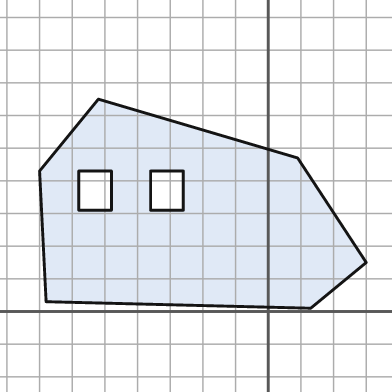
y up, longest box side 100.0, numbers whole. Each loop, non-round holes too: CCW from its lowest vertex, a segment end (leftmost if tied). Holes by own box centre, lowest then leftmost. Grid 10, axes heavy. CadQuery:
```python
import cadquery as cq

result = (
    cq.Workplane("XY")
    .moveTo(13.0, 1.0)
    .lineTo(30.0, 15.0)
    .lineTo(9.0, 47.0)
    .lineTo(-52.0, 65.0)
    .lineTo(-70.0, 43.0)
    .lineTo(-68.0, 3.0)
    .close()
    .moveTo(-58.0, 31.0)
    .lineTo(-48.0, 31.0)
    .lineTo(-48.0, 43.0)
    .lineTo(-58.0, 43.0)
    .close()
    .moveTo(-36.0, 31.0)
    .lineTo(-26.0, 31.0)
    .lineTo(-26.0, 43.0)
    .lineTo(-36.0, 43.0)
    .close()
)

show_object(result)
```